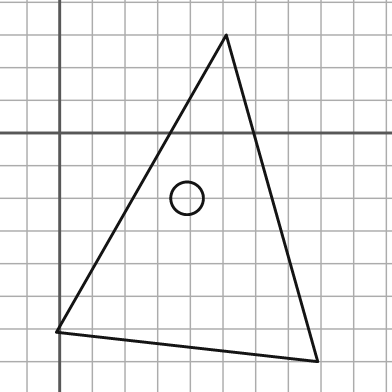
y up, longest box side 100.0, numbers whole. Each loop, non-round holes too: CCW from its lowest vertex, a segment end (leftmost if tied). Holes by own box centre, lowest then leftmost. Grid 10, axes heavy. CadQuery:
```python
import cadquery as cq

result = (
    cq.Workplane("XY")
    .moveTo(79.0, -70.0)
    .lineTo(51.0, 30.0)
    .lineTo(-1.0, -61.0)
    .close()
    .moveTo(39.0, -20.0)
    .circle(5.0)
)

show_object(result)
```